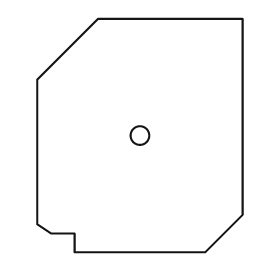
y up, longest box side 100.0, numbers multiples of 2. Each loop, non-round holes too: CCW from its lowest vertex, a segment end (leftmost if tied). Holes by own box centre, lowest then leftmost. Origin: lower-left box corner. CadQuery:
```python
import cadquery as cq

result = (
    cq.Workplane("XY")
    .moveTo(16.0, 0.0)
    .lineTo(72.0, 0.0)
    .lineTo(88.0, 16.0)
    .lineTo(88.0, 100.0)
    .lineTo(26.0, 100.0)
    .lineTo(0.0, 74.0)
    .lineTo(0.0, 12.0)
    .lineTo(6.0, 8.0)
    .lineTo(16.0, 8.0)
    .close()
    .moveTo(44.0, 50.0)
    .circle(4.0)
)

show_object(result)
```